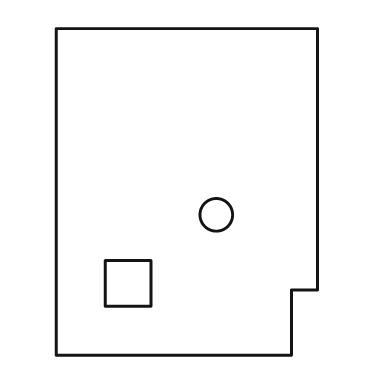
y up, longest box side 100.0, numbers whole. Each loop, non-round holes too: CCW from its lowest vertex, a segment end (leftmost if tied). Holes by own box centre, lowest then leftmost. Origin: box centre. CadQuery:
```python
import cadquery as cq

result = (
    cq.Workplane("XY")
    .moveTo(-40.0, -50.0)
    .lineTo(32.0, -50.0)
    .lineTo(32.0, -30.0)
    .lineTo(40.0, -30.0)
    .lineTo(40.0, 50.0)
    .lineTo(-40.0, 50.0)
    .close()
    .moveTo(-25.0, -35.0)
    .lineTo(-11.0, -35.0)
    .lineTo(-11.0, -21.0)
    .lineTo(-25.0, -21.0)
    .close()
    .moveTo(9.0, -7.0)
    .circle(5.0)
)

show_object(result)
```